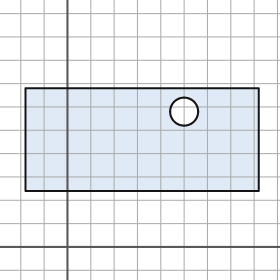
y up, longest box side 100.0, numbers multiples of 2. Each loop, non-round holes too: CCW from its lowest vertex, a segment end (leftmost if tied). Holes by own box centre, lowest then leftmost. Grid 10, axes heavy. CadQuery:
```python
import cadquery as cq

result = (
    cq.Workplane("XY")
    .moveTo(-18.0, 24.0)
    .lineTo(82.0, 24.0)
    .lineTo(82.0, 68.0)
    .lineTo(-18.0, 68.0)
    .close()
    .moveTo(50.0, 58.0)
    .circle(6.0)
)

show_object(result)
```